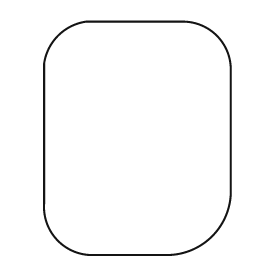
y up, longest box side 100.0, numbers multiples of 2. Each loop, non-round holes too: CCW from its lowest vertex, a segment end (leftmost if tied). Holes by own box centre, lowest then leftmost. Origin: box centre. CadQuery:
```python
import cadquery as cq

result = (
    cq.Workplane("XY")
    .moveTo(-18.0, -50.0)
    .lineTo(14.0, -50.0)
    .threePointArc((32.0, -42.0), (40.0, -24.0))
    .lineTo(40.0, 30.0)
    .threePointArc((34.0, 44.0), (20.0, 50.0))
    .lineTo(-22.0, 50.0)
    .threePointArc((-34.0, 44.0), (-40.0, 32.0))
    .lineTo(-40.0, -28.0)
    .threePointArc((-34.0, -44.0), (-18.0, -50.0))
    .close()
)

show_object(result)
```